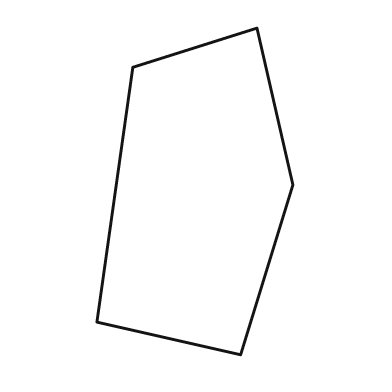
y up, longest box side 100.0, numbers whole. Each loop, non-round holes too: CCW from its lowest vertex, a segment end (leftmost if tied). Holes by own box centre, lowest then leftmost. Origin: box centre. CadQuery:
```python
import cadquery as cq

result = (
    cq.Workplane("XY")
    .moveTo(14.0, -50.0)
    .lineTo(30.0, 2.0)
    .lineTo(19.0, 50.0)
    .lineTo(-19.0, 38.0)
    .lineTo(-30.0, -40.0)
    .close()
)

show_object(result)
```